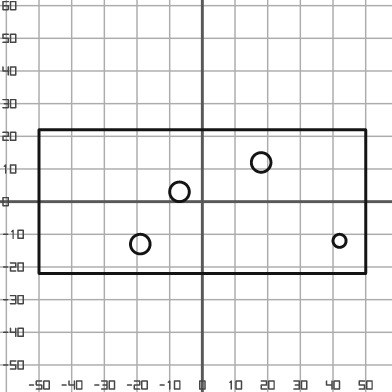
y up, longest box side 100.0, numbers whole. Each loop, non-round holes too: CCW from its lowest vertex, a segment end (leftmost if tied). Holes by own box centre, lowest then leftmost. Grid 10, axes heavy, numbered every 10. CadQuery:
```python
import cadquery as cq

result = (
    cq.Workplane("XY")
    .moveTo(-50.0, -22.0)
    .lineTo(50.0, -22.0)
    .lineTo(50.0, 22.0)
    .lineTo(-50.0, 22.0)
    .close()
    .moveTo(-19.0, -13.0)
    .circle(3.0)
    .moveTo(42.0, -12.0)
    .circle(2.0)
    .moveTo(-7.0, 3.0)
    .circle(3.0)
    .moveTo(18.0, 12.0)
    .circle(3.0)
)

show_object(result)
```